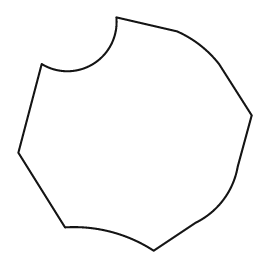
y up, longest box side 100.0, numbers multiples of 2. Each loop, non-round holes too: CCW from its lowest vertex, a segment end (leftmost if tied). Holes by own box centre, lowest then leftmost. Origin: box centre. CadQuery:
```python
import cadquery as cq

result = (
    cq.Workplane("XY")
    .moveTo(8.0, -50.0)
    .lineTo(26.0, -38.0)
    .threePointArc((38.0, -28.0), (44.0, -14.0))
    .lineTo(50.0, 8.0)
    .lineTo(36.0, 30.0)
    .threePointArc((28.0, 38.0), (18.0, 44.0))
    .lineTo(-8.0, 50.0)
    .threePointArc((-18.0, 30.0), (-40.0, 30.0))
    .lineTo(-50.0, -8.0)
    .lineTo(-30.0, -40.0)
    .threePointArc((-10.0, -42.0), (8.0, -50.0))
    .close()
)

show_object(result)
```